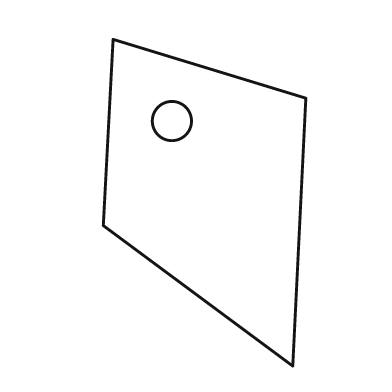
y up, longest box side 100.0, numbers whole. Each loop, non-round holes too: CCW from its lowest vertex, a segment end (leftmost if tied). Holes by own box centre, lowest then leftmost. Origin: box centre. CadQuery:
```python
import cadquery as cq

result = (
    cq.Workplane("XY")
    .moveTo(27.0, -50.0)
    .lineTo(31.0, 32.0)
    .lineTo(-28.0, 50.0)
    .lineTo(-31.0, -7.0)
    .close()
    .moveTo(-10.0, 25.0)
    .circle(6.0)
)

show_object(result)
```